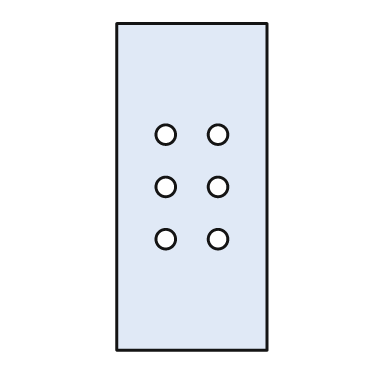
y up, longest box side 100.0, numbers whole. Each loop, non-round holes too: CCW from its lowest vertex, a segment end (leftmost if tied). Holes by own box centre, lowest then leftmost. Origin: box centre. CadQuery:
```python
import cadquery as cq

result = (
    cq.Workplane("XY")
    .moveTo(-23.0, -50.0)
    .lineTo(23.0, -50.0)
    .lineTo(23.0, 50.0)
    .lineTo(-23.0, 50.0)
    .close()
    .moveTo(-8.0, -16.0)
    .circle(3.0)
    .moveTo(8.0, -16.0)
    .circle(3.0)
    .moveTo(-8.0, 0.0)
    .circle(3.0)
    .moveTo(8.0, 0.0)
    .circle(3.0)
    .moveTo(-8.0, 16.0)
    .circle(3.0)
    .moveTo(8.0, 16.0)
    .circle(3.0)
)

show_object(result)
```